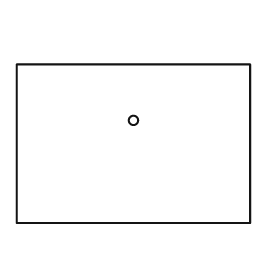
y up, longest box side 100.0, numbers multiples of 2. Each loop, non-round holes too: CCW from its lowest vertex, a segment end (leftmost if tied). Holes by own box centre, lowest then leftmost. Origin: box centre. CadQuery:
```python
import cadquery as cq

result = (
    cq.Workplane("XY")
    .moveTo(-50.0, -34.0)
    .lineTo(50.0, -34.0)
    .lineTo(50.0, 34.0)
    .lineTo(-50.0, 34.0)
    .close()
    .moveTo(0.0, 10.0)
    .circle(2.0)
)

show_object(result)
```